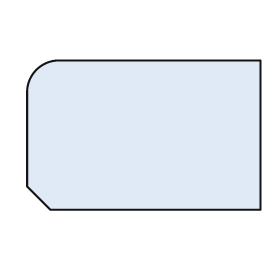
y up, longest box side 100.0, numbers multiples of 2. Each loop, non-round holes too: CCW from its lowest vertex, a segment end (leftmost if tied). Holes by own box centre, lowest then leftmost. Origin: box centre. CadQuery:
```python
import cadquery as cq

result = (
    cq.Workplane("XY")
    .moveTo(-40.0, -32.0)
    .lineTo(50.0, -32.0)
    .lineTo(50.0, 32.0)
    .lineTo(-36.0, 32.0)
    .threePointArc((-46.0, 28.0), (-50.0, 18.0))
    .lineTo(-50.0, -22.0)
    .close()
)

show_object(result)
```